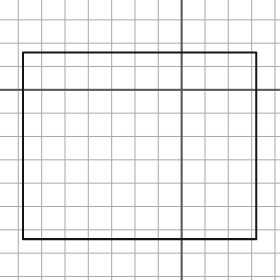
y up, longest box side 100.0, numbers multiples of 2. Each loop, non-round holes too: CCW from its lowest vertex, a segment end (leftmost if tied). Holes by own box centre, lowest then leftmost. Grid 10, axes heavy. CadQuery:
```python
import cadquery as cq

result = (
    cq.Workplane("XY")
    .moveTo(-68.0, -64.0)
    .lineTo(32.0, -64.0)
    .lineTo(32.0, 16.0)
    .lineTo(-68.0, 16.0)
    .close()
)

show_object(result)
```